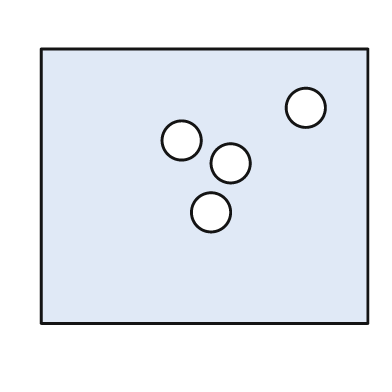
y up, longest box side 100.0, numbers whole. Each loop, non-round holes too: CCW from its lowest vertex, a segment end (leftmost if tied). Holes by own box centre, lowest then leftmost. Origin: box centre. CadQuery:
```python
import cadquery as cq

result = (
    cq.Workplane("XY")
    .moveTo(-50.0, -42.0)
    .lineTo(50.0, -42.0)
    .lineTo(50.0, 42.0)
    .lineTo(-50.0, 42.0)
    .close()
    .moveTo(2.0, -8.0)
    .circle(6.0)
    .moveTo(8.0, 7.0)
    .circle(6.0)
    .moveTo(-7.0, 14.0)
    .circle(6.0)
    .moveTo(31.0, 24.0)
    .circle(6.0)
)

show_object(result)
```